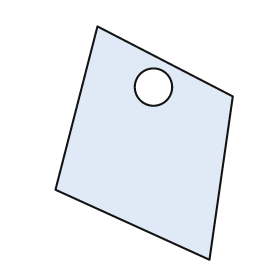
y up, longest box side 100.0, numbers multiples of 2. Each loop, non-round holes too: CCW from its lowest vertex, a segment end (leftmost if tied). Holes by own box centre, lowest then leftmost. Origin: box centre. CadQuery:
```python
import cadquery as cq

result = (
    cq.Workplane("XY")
    .moveTo(28.0, -50.0)
    .lineTo(38.0, 20.0)
    .lineTo(-20.0, 50.0)
    .lineTo(-38.0, -20.0)
    .close()
    .moveTo(4.0, 24.0)
    .circle(8.0)
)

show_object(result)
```